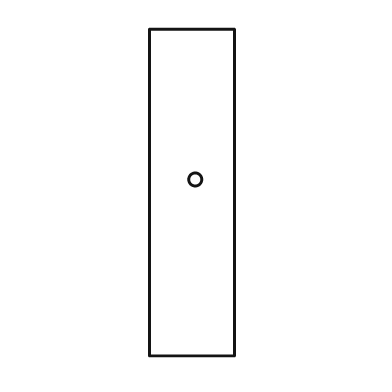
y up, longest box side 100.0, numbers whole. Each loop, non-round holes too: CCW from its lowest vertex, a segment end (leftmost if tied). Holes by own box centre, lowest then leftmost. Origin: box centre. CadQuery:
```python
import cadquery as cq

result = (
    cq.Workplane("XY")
    .moveTo(-13.0, -50.0)
    .lineTo(13.0, -50.0)
    .lineTo(13.0, 50.0)
    .lineTo(-13.0, 50.0)
    .close()
    .moveTo(1.0, 4.0)
    .circle(2.0)
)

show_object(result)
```